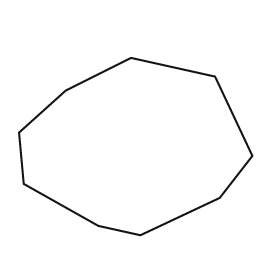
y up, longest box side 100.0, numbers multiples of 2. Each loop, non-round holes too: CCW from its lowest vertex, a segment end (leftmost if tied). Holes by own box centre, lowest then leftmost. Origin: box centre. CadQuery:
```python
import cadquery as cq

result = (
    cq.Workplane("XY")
    .moveTo(2.0, -38.0)
    .lineTo(36.0, -22.0)
    .lineTo(50.0, -4.0)
    .lineTo(34.0, 30.0)
    .lineTo(-2.0, 38.0)
    .lineTo(-30.0, 24.0)
    .lineTo(-50.0, 6.0)
    .lineTo(-48.0, -16.0)
    .lineTo(-16.0, -34.0)
    .close()
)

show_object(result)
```